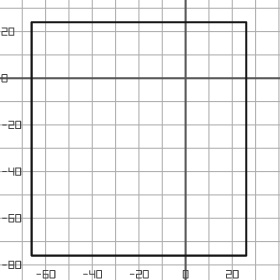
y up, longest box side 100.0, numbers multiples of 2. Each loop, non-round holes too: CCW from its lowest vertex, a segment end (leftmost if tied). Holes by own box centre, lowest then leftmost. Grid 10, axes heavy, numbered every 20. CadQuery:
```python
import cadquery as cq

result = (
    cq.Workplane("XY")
    .moveTo(-66.0, -76.0)
    .lineTo(26.0, -76.0)
    .lineTo(26.0, 24.0)
    .lineTo(-66.0, 24.0)
    .close()
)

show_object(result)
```